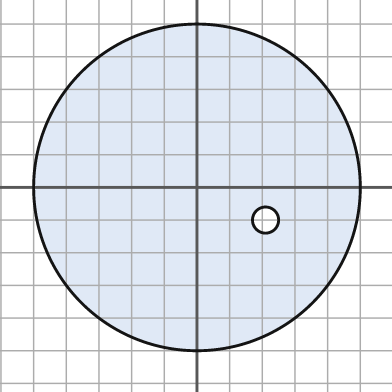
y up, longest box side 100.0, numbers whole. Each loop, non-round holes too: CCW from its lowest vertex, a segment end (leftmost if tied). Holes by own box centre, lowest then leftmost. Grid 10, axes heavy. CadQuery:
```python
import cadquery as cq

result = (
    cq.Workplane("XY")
    .moveTo(0.0, 0.0)
    .circle(50.0)
    .moveTo(21.0, -10.0)
    .circle(4.0)
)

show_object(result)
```